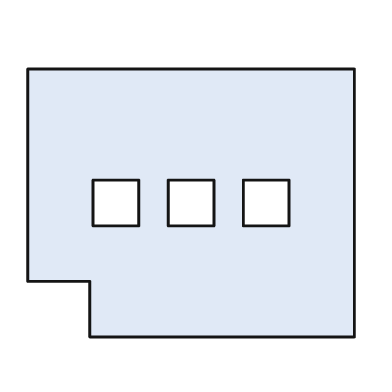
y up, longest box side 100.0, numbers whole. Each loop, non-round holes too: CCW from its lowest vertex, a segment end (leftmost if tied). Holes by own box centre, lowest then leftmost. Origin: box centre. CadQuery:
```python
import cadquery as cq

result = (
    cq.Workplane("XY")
    .moveTo(-31.0, -41.0)
    .lineTo(50.0, -41.0)
    .lineTo(50.0, 41.0)
    .lineTo(-50.0, 41.0)
    .lineTo(-50.0, -24.0)
    .lineTo(-31.0, -24.0)
    .close()
    .moveTo(-30.0, -7.0)
    .lineTo(-16.0, -7.0)
    .lineTo(-16.0, 7.0)
    .lineTo(-30.0, 7.0)
    .close()
    .moveTo(-7.0, -7.0)
    .lineTo(7.0, -7.0)
    .lineTo(7.0, 7.0)
    .lineTo(-7.0, 7.0)
    .close()
    .moveTo(16.0, -7.0)
    .lineTo(30.0, -7.0)
    .lineTo(30.0, 7.0)
    .lineTo(16.0, 7.0)
    .close()
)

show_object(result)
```